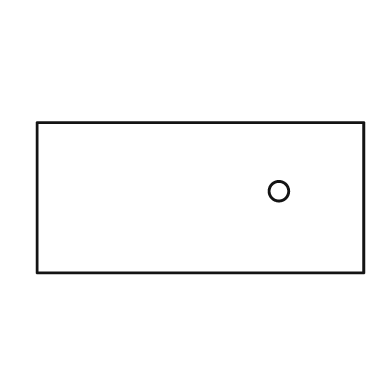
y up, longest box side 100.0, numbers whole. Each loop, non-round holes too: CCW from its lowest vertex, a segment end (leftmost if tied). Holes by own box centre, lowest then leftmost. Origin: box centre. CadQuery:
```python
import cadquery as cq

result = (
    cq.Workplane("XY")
    .moveTo(-50.0, -23.0)
    .lineTo(50.0, -23.0)
    .lineTo(50.0, 23.0)
    .lineTo(-50.0, 23.0)
    .close()
    .moveTo(24.0, 2.0)
    .circle(3.0)
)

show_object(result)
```